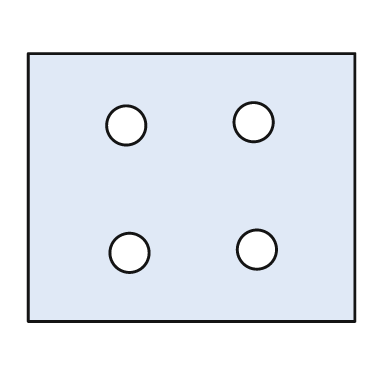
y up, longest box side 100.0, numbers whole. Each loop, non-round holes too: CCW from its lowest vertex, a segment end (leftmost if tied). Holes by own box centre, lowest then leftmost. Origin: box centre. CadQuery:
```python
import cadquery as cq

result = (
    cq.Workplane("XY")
    .moveTo(-50.0, -41.0)
    .lineTo(50.0, -41.0)
    .lineTo(50.0, 41.0)
    .lineTo(-50.0, 41.0)
    .close()
    .moveTo(-19.0, -20.0)
    .circle(6.0)
    .moveTo(20.0, -19.0)
    .circle(6.0)
    .moveTo(-20.0, 19.0)
    .circle(6.0)
    .moveTo(19.0, 20.0)
    .circle(6.0)
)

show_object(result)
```